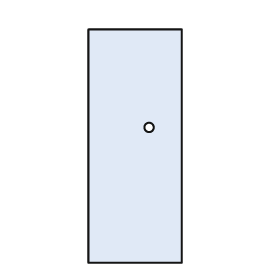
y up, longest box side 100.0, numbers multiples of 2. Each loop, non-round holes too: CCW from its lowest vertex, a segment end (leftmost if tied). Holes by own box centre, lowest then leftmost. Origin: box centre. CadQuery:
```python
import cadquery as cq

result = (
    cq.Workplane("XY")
    .moveTo(-20.0, -50.0)
    .lineTo(20.0, -50.0)
    .lineTo(20.0, 50.0)
    .lineTo(-20.0, 50.0)
    .close()
    .moveTo(6.0, 8.0)
    .circle(2.0)
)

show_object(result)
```